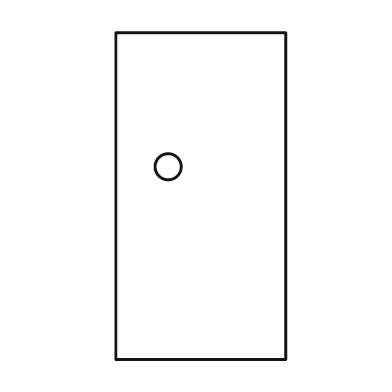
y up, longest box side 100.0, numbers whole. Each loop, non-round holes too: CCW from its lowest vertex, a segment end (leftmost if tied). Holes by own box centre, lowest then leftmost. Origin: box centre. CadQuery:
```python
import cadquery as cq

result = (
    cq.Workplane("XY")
    .moveTo(-26.0, -50.0)
    .lineTo(26.0, -50.0)
    .lineTo(26.0, 50.0)
    .lineTo(-26.0, 50.0)
    .close()
    .moveTo(-10.0, 9.0)
    .circle(4.0)
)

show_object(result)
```